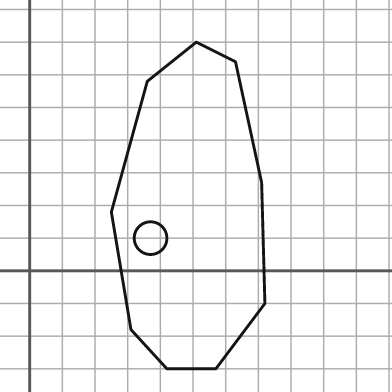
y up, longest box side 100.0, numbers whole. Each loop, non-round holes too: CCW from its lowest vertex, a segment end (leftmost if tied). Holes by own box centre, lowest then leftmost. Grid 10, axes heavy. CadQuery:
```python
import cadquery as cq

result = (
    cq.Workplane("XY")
    .moveTo(42.0, -30.0)
    .lineTo(57.0, -30.0)
    .lineTo(72.0, -10.0)
    .lineTo(71.0, 27.0)
    .lineTo(63.0, 64.0)
    .lineTo(51.0, 70.0)
    .lineTo(36.0, 58.0)
    .lineTo(25.0, 18.0)
    .lineTo(31.0, -18.0)
    .close()
    .moveTo(37.0, 10.0)
    .circle(5.0)
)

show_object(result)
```